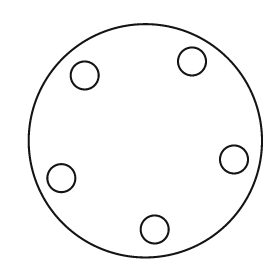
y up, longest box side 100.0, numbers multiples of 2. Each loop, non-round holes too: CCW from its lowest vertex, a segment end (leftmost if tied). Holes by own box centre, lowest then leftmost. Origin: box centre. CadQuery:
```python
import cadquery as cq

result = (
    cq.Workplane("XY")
    .moveTo(0.0, 0.0)
    .circle(50.0)
    .moveTo(4.0, -38.0)
    .circle(6.0)
    .moveTo(-36.0, -16.0)
    .circle(6.0)
    .moveTo(38.0, -8.0)
    .circle(6.0)
    .moveTo(-26.0, 28.0)
    .circle(6.0)
    .moveTo(20.0, 34.0)
    .circle(6.0)
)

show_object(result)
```